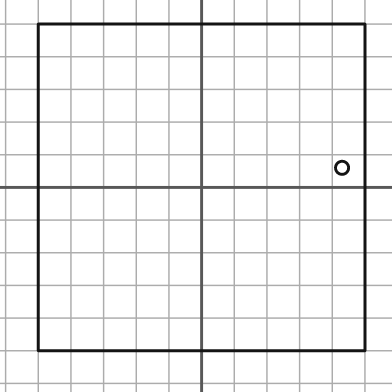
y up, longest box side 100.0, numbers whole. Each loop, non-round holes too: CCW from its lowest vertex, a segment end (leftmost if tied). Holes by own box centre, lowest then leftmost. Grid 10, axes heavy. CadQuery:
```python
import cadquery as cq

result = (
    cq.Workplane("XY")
    .moveTo(-50.0, -50.0)
    .lineTo(50.0, -50.0)
    .lineTo(50.0, 50.0)
    .lineTo(-50.0, 50.0)
    .close()
    .moveTo(43.0, 6.0)
    .circle(2.0)
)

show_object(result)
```